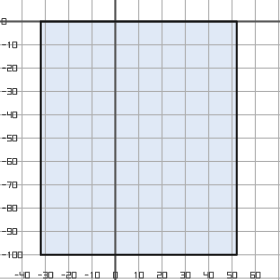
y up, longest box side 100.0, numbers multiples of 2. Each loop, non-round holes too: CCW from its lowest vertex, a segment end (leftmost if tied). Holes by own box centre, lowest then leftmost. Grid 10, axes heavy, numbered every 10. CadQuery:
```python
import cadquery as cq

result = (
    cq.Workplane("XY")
    .moveTo(-32.0, -100.0)
    .lineTo(52.0, -100.0)
    .lineTo(52.0, 0.0)
    .lineTo(-32.0, 0.0)
    .close()
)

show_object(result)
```